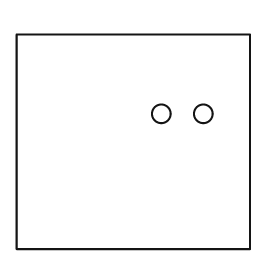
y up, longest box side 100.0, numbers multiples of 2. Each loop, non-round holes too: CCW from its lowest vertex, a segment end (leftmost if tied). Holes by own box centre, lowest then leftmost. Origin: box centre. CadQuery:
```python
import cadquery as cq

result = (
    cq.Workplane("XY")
    .moveTo(-50.0, -46.0)
    .lineTo(50.0, -46.0)
    .lineTo(50.0, 46.0)
    .lineTo(-50.0, 46.0)
    .close()
    .moveTo(12.0, 12.0)
    .circle(4.0)
    .moveTo(30.0, 12.0)
    .circle(4.0)
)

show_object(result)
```